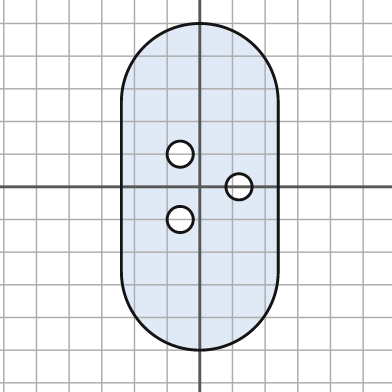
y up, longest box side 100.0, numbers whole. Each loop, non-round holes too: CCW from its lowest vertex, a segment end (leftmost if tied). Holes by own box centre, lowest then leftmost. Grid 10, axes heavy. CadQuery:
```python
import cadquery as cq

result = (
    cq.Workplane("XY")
    .moveTo(-24.0, -26.0)
    .threePointArc((0.0, -50.0), (24.0, -26.0))
    .lineTo(24.0, 26.0)
    .threePointArc((0.0, 50.0), (-24.0, 26.0))
    .close()
    .moveTo(-6.0, -10.0)
    .circle(4.0)
    .moveTo(12.0, 0.0)
    .circle(4.0)
    .moveTo(-6.0, 10.0)
    .circle(4.0)
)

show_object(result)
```